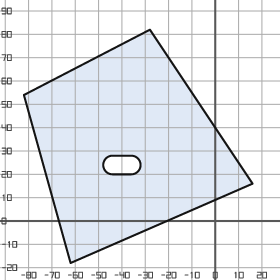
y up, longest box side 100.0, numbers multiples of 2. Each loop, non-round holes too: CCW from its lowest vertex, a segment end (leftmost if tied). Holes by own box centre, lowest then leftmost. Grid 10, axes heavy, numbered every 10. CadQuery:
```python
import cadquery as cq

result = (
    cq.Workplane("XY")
    .moveTo(-62.0, -18.0)
    .lineTo(16.0, 16.0)
    .lineTo(-28.0, 82.0)
    .lineTo(-82.0, 54.0)
    .close()
    .moveTo(-44.0, 20.0)
    .lineTo(-36.0, 20.0)
    .threePointArc((-32.0, 24.0), (-36.0, 28.0))
    .lineTo(-44.0, 28.0)
    .threePointArc((-48.0, 24.0), (-44.0, 20.0))
    .close()
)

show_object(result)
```